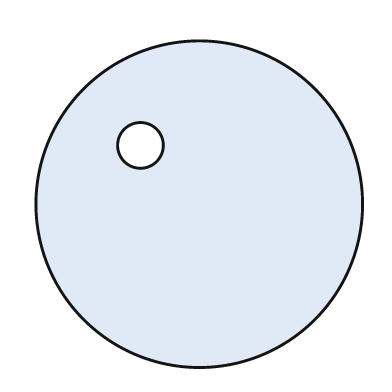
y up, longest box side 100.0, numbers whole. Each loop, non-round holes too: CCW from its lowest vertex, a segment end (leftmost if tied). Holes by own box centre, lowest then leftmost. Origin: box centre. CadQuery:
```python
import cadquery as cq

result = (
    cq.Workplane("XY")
    .moveTo(0.0, 0.0)
    .circle(50.0)
    .moveTo(-18.0, 18.0)
    .circle(7.0)
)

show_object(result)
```